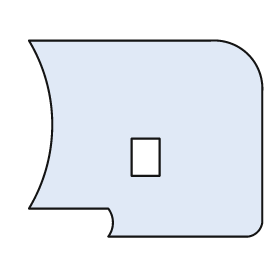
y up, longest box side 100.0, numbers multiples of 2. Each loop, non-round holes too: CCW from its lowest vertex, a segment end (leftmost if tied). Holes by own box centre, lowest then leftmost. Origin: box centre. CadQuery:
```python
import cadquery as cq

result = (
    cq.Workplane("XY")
    .moveTo(-16.0, -42.0)
    .lineTo(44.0, -42.0)
    .threePointArc((48.0, -40.0), (50.0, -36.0))
    .lineTo(50.0, 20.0)
    .threePointArc((44.0, 36.0), (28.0, 42.0))
    .lineTo(-50.0, 42.0)
    .threePointArc((-40.0, 6.0), (-50.0, -30.0))
    .lineTo(-16.0, -30.0)
    .threePointArc((-14.0, -36.0), (-16.0, -42.0))
    .close()
    .moveTo(-6.0, -16.0)
    .lineTo(6.0, -16.0)
    .lineTo(6.0, 0.0)
    .lineTo(-6.0, 0.0)
    .close()
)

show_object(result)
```